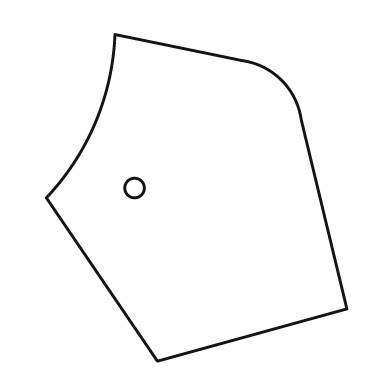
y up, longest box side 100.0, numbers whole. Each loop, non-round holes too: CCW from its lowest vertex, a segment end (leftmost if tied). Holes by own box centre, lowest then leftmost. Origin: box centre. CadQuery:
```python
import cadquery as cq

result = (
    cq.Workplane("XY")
    .moveTo(-12.0, -50.0)
    .lineTo(46.0, -34.0)
    .lineTo(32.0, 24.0)
    .threePointArc((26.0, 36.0), (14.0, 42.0))
    .lineTo(-25.0, 50.0)
    .threePointArc((-31.0, 23.0), (-46.0, 0.0))
    .close()
    .moveTo(-19.0, 3.0)
    .circle(3.0)
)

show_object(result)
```